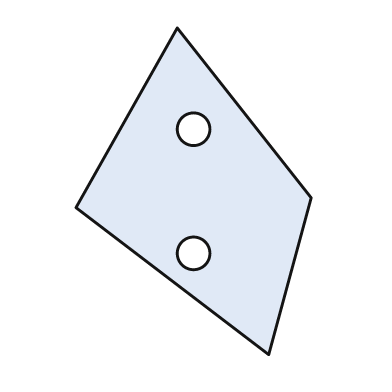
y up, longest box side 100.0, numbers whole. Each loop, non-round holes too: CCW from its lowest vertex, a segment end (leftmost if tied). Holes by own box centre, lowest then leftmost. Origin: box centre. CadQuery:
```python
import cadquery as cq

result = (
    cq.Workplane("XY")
    .moveTo(23.0, -50.0)
    .lineTo(36.0, -2.0)
    .lineTo(-5.0, 50.0)
    .lineTo(-36.0, -5.0)
    .close()
    .moveTo(0.0, -19.0)
    .circle(5.0)
    .moveTo(0.0, 19.0)
    .circle(5.0)
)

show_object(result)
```